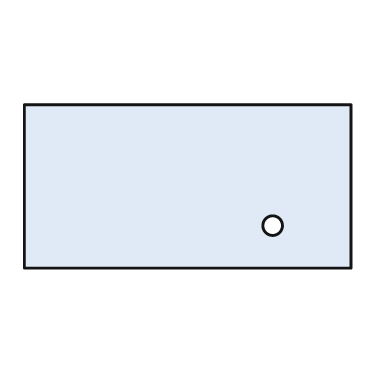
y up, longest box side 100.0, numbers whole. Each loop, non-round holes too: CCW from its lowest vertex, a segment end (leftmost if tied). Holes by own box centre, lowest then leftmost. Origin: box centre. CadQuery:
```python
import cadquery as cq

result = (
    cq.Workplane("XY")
    .moveTo(-50.0, -25.0)
    .lineTo(50.0, -25.0)
    .lineTo(50.0, 25.0)
    .lineTo(-50.0, 25.0)
    .close()
    .moveTo(26.0, -12.0)
    .circle(3.0)
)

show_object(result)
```